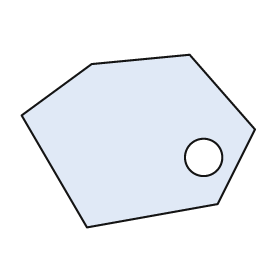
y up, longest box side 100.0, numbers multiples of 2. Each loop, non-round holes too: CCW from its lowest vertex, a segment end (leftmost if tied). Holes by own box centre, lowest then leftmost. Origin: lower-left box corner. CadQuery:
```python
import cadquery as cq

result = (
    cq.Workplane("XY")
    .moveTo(28.0, 0.0)
    .lineTo(84.0, 10.0)
    .lineTo(100.0, 42.0)
    .lineTo(72.0, 74.0)
    .lineTo(30.0, 70.0)
    .lineTo(0.0, 48.0)
    .close()
    .moveTo(78.0, 30.0)
    .circle(8.0)
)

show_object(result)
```